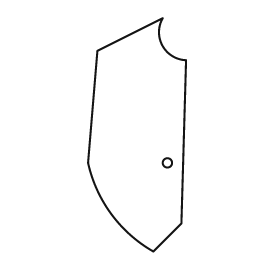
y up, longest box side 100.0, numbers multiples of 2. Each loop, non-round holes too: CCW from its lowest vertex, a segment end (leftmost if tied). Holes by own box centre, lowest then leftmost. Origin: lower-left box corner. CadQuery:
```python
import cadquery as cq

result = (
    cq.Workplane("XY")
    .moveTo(28.0, 0.0)
    .lineTo(40.0, 12.0)
    .lineTo(42.0, 82.0)
    .threePointArc((32.0, 88.0), (32.0, 100.0))
    .lineTo(4.0, 86.0)
    .lineTo(0.0, 38.0)
    .threePointArc((10.0, 16.0), (28.0, 0.0))
    .close()
    .moveTo(34.0, 38.0)
    .circle(2.0)
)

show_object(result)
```